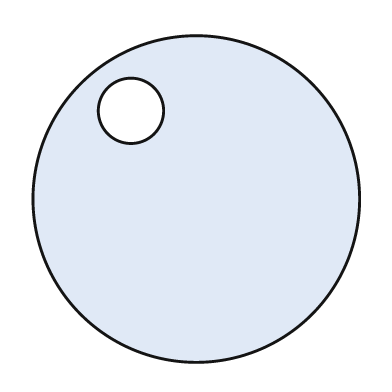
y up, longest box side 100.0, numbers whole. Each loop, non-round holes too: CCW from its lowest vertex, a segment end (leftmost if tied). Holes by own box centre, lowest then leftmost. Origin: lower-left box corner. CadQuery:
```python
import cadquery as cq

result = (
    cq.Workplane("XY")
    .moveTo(50.0, 50.0)
    .circle(50.0)
    .moveTo(30.0, 77.0)
    .circle(10.0)
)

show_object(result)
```